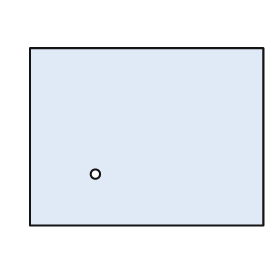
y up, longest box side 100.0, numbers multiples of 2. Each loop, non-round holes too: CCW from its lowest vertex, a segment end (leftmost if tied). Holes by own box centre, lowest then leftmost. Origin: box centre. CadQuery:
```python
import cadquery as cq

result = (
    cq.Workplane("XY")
    .moveTo(-50.0, -38.0)
    .lineTo(50.0, -38.0)
    .lineTo(50.0, 38.0)
    .lineTo(-50.0, 38.0)
    .close()
    .moveTo(-22.0, -16.0)
    .circle(2.0)
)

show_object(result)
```